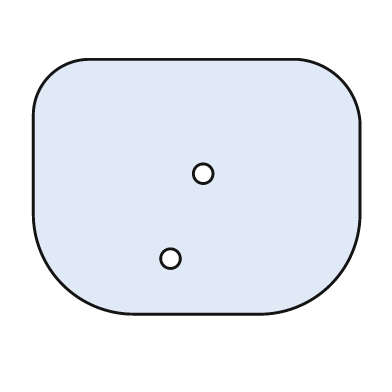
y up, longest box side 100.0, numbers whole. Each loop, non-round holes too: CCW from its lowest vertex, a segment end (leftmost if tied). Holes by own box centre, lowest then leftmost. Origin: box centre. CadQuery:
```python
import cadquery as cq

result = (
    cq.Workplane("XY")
    .moveTo(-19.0, -39.0)
    .lineTo(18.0, -39.0)
    .threePointArc((41.0, -30.0), (50.0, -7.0))
    .lineTo(50.0, 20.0)
    .threePointArc((44.0, 33.0), (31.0, 39.0))
    .lineTo(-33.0, 39.0)
    .threePointArc((-45.0, 34.0), (-50.0, 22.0))
    .lineTo(-50.0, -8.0)
    .threePointArc((-41.0, -30.0), (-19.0, -39.0))
    .close()
    .moveTo(-8.0, -22.0)
    .circle(3.0)
    .moveTo(2.0, 4.0)
    .circle(3.0)
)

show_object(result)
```